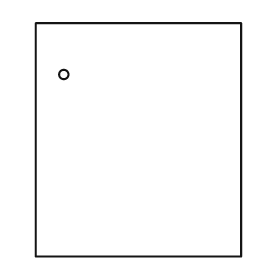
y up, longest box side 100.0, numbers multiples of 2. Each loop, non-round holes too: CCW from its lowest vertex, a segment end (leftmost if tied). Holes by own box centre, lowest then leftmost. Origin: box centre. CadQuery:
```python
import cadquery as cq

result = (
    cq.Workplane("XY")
    .moveTo(-44.0, -50.0)
    .lineTo(44.0, -50.0)
    .lineTo(44.0, 50.0)
    .lineTo(-44.0, 50.0)
    .close()
    .moveTo(-32.0, 28.0)
    .circle(2.0)
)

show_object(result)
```